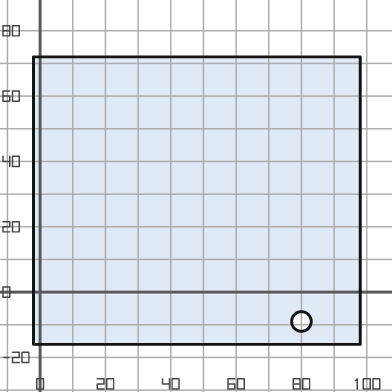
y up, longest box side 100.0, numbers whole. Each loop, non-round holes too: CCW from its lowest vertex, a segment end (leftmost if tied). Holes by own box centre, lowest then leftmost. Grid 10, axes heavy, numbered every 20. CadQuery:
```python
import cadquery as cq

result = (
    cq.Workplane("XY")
    .moveTo(-2.0, -16.0)
    .lineTo(98.0, -16.0)
    .lineTo(98.0, 72.0)
    .lineTo(-2.0, 72.0)
    .close()
    .moveTo(80.0, -9.0)
    .circle(3.0)
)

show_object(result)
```